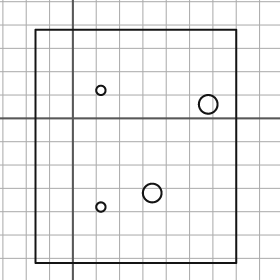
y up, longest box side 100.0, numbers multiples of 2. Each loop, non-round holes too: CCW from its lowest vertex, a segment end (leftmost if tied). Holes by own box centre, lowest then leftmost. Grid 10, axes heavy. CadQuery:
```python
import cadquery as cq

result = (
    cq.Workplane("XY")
    .moveTo(-16.0, -62.0)
    .lineTo(70.0, -62.0)
    .lineTo(70.0, 38.0)
    .lineTo(-16.0, 38.0)
    .close()
    .moveTo(12.0, -38.0)
    .circle(2.0)
    .moveTo(34.0, -32.0)
    .circle(4.0)
    .moveTo(58.0, 6.0)
    .circle(4.0)
    .moveTo(12.0, 12.0)
    .circle(2.0)
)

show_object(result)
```